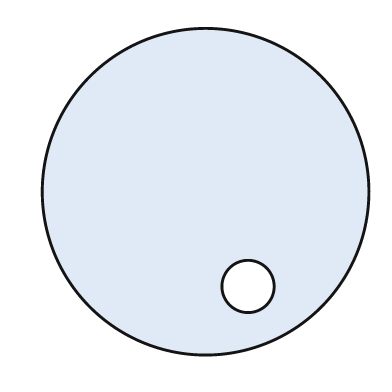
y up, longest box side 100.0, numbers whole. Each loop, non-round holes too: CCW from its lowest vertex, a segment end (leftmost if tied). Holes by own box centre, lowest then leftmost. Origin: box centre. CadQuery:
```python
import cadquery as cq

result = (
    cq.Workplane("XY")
    .moveTo(0.0, 0.0)
    .circle(50.0)
    .moveTo(13.0, -29.0)
    .circle(8.0)
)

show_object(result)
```